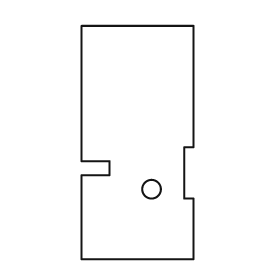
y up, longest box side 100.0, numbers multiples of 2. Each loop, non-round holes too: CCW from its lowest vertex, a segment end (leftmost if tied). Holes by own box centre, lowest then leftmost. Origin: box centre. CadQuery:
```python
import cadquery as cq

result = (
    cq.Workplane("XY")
    .moveTo(-24.0, -50.0)
    .lineTo(24.0, -50.0)
    .lineTo(24.0, -24.0)
    .lineTo(20.0, -24.0)
    .lineTo(20.0, -2.0)
    .lineTo(24.0, -2.0)
    .lineTo(24.0, 50.0)
    .lineTo(-24.0, 50.0)
    .lineTo(-24.0, -8.0)
    .lineTo(-12.0, -8.0)
    .lineTo(-12.0, -14.0)
    .lineTo(-24.0, -14.0)
    .close()
    .moveTo(6.0, -20.0)
    .circle(4.0)
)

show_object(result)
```